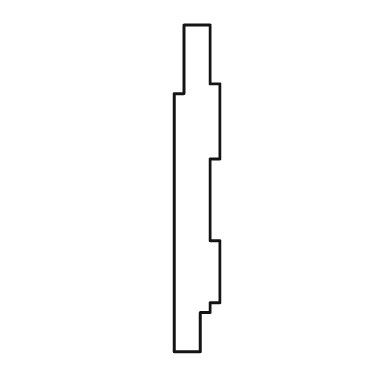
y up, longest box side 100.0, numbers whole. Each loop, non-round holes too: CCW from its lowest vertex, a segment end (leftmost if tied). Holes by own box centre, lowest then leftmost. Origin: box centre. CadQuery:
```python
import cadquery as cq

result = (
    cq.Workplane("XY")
    .moveTo(-7.0, -50.0)
    .lineTo(1.0, -50.0)
    .lineTo(1.0, -38.0)
    .lineTo(4.0, -38.0)
    .lineTo(4.0, -35.0)
    .lineTo(7.0, -35.0)
    .lineTo(7.0, -16.0)
    .lineTo(4.0, -16.0)
    .lineTo(4.0, 9.0)
    .lineTo(7.0, 9.0)
    .lineTo(7.0, 32.0)
    .lineTo(4.0, 32.0)
    .lineTo(4.0, 50.0)
    .lineTo(-4.0, 50.0)
    .lineTo(-4.0, 29.0)
    .lineTo(-7.0, 29.0)
    .close()
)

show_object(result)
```